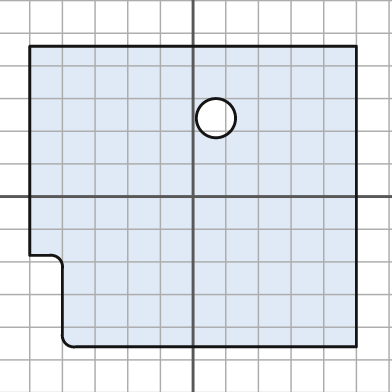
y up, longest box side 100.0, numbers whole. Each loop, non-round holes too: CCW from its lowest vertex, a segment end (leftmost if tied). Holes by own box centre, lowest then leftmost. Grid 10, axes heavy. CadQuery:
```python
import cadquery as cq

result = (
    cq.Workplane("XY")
    .moveTo(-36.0, -46.0)
    .lineTo(50.0, -46.0)
    .lineTo(50.0, 46.0)
    .lineTo(-50.0, 46.0)
    .lineTo(-50.0, -18.0)
    .lineTo(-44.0, -18.0)
    .threePointArc((-41.0, -19.0), (-40.0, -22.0))
    .lineTo(-40.0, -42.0)
    .threePointArc((-39.0, -45.0), (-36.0, -46.0))
    .close()
    .moveTo(7.0, 24.0)
    .circle(6.0)
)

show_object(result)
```